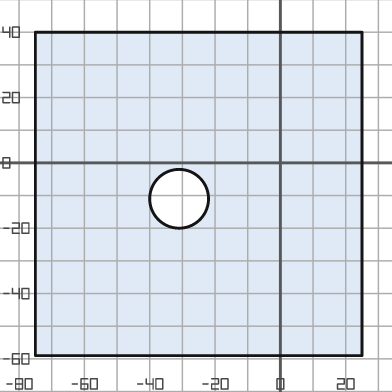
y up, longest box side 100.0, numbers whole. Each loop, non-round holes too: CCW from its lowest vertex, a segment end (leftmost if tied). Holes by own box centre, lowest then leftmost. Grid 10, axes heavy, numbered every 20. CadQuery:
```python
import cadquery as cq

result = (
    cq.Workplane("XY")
    .moveTo(-75.0, -59.0)
    .lineTo(25.0, -59.0)
    .lineTo(25.0, 40.0)
    .lineTo(-75.0, 40.0)
    .close()
    .moveTo(-31.0, -11.0)
    .circle(9.0)
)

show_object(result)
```